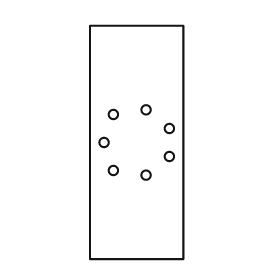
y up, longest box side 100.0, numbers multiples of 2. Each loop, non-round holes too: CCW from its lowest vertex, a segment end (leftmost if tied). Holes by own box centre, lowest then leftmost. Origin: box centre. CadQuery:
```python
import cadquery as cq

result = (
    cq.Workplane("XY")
    .moveTo(-20.0, -50.0)
    .lineTo(20.0, -50.0)
    .lineTo(20.0, 50.0)
    .lineTo(-20.0, 50.0)
    .close()
    .moveTo(4.0, -14.0)
    .circle(2.0)
    .moveTo(-10.0, -12.0)
    .circle(2.0)
    .moveTo(14.0, -6.0)
    .circle(2.0)
    .moveTo(-14.0, 0.0)
    .circle(2.0)
    .moveTo(14.0, 6.0)
    .circle(2.0)
    .moveTo(-10.0, 12.0)
    .circle(2.0)
    .moveTo(4.0, 14.0)
    .circle(2.0)
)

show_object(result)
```